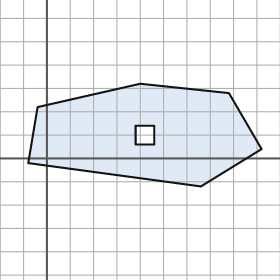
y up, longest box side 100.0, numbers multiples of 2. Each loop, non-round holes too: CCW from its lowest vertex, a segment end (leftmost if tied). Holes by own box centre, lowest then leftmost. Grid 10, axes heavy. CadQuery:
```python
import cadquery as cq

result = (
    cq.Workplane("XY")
    .moveTo(66.0, -12.0)
    .lineTo(92.0, 4.0)
    .lineTo(78.0, 28.0)
    .lineTo(40.0, 32.0)
    .lineTo(-4.0, 22.0)
    .lineTo(-8.0, -2.0)
    .close()
    .moveTo(38.0, 6.0)
    .lineTo(46.0, 6.0)
    .lineTo(46.0, 14.0)
    .lineTo(38.0, 14.0)
    .close()
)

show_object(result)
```